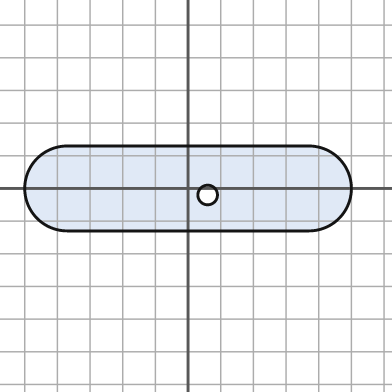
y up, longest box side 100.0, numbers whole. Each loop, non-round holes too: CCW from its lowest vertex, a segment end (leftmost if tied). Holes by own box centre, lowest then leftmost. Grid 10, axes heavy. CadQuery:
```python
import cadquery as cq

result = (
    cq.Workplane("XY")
    .moveTo(-37.0, -13.0)
    .lineTo(37.0, -13.0)
    .threePointArc((50.0, 0.0), (37.0, 13.0))
    .lineTo(-37.0, 13.0)
    .threePointArc((-50.0, 0.0), (-37.0, -13.0))
    .close()
    .moveTo(6.0, -2.0)
    .circle(3.0)
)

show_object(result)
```